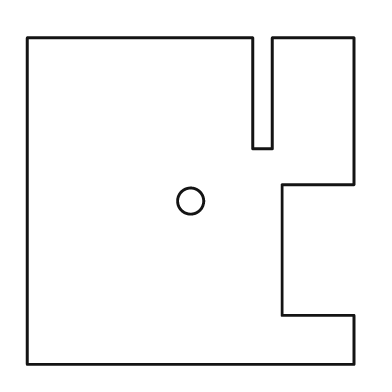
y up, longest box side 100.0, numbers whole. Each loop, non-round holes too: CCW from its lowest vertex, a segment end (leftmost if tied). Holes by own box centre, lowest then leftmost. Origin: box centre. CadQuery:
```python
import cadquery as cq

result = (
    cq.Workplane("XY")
    .moveTo(-50.0, -50.0)
    .lineTo(50.0, -50.0)
    .lineTo(50.0, -35.0)
    .lineTo(28.0, -35.0)
    .lineTo(28.0, 5.0)
    .lineTo(50.0, 5.0)
    .lineTo(50.0, 50.0)
    .lineTo(25.0, 50.0)
    .lineTo(25.0, 16.0)
    .lineTo(19.0, 16.0)
    .lineTo(19.0, 50.0)
    .lineTo(-50.0, 50.0)
    .close()
    .moveTo(0.0, 0.0)
    .circle(4.0)
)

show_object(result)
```